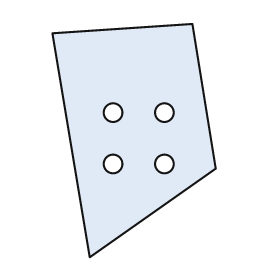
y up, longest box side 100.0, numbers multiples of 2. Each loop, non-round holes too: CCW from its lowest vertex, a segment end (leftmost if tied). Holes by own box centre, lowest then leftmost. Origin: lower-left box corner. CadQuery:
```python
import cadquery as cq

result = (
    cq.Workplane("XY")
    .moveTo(16.0, 0.0)
    .lineTo(70.0, 38.0)
    .lineTo(60.0, 100.0)
    .lineTo(0.0, 96.0)
    .close()
    .moveTo(26.0, 40.0)
    .circle(4.0)
    .moveTo(48.0, 40.0)
    .circle(4.0)
    .moveTo(26.0, 62.0)
    .circle(4.0)
    .moveTo(48.0, 62.0)
    .circle(4.0)
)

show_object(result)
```